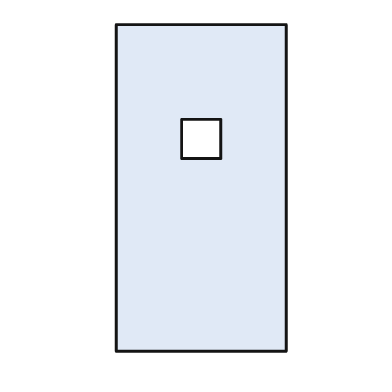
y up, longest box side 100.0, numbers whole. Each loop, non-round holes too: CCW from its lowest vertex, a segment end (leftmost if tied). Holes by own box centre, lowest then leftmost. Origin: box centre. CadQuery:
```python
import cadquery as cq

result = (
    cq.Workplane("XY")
    .moveTo(-26.0, -50.0)
    .lineTo(26.0, -50.0)
    .lineTo(26.0, 50.0)
    .lineTo(-26.0, 50.0)
    .close()
    .moveTo(-6.0, 9.0)
    .lineTo(6.0, 9.0)
    .lineTo(6.0, 21.0)
    .lineTo(-6.0, 21.0)
    .close()
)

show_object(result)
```